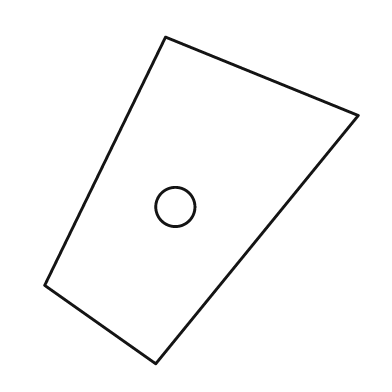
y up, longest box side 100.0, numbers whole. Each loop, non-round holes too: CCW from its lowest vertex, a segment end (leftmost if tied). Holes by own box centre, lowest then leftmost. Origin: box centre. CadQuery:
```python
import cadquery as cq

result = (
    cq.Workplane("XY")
    .moveTo(-14.0, -50.0)
    .lineTo(48.0, 26.0)
    .lineTo(-11.0, 50.0)
    .lineTo(-48.0, -26.0)
    .close()
    .moveTo(-8.0, -2.0)
    .circle(6.0)
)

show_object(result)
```